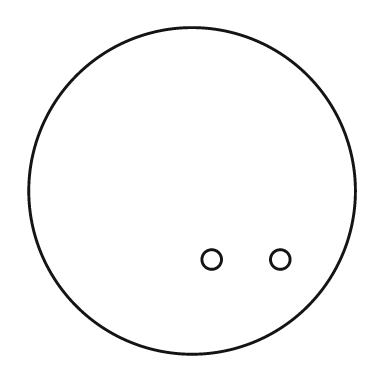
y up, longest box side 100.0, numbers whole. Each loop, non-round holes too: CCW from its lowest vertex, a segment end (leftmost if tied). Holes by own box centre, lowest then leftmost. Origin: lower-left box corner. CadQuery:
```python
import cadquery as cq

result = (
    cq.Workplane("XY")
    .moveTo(50.0, 50.0)
    .circle(50.0)
    .moveTo(56.0, 29.0)
    .circle(3.0)
    .moveTo(77.0, 29.0)
    .circle(3.0)
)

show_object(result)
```